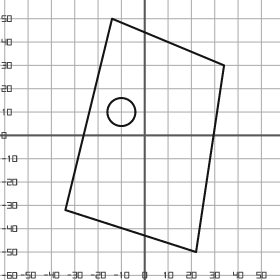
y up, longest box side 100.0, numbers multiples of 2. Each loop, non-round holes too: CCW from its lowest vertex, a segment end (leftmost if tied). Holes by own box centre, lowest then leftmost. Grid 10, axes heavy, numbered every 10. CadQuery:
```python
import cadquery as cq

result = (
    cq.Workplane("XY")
    .moveTo(22.0, -50.0)
    .lineTo(34.0, 30.0)
    .lineTo(-14.0, 50.0)
    .lineTo(-34.0, -32.0)
    .close()
    .moveTo(-10.0, 10.0)
    .circle(6.0)
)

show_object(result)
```